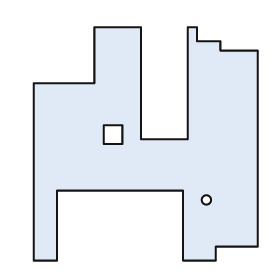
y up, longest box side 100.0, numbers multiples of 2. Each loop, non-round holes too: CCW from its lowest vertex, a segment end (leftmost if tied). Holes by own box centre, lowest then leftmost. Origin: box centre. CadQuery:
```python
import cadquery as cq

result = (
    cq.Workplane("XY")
    .moveTo(-48.0, -50.0)
    .lineTo(-38.0, -50.0)
    .lineTo(-38.0, -20.0)
    .lineTo(16.0, -20.0)
    .lineTo(16.0, -50.0)
    .lineTo(30.0, -50.0)
    .lineTo(30.0, -44.0)
    .lineTo(48.0, -44.0)
    .lineTo(48.0, 40.0)
    .lineTo(32.0, 40.0)
    .lineTo(32.0, 44.0)
    .lineTo(22.0, 44.0)
    .lineTo(22.0, 50.0)
    .lineTo(18.0, 50.0)
    .lineTo(18.0, 2.0)
    .lineTo(-2.0, 2.0)
    .lineTo(-2.0, 50.0)
    .lineTo(-22.0, 50.0)
    .lineTo(-22.0, 26.0)
    .lineTo(-48.0, 26.0)
    .close()
    .moveTo(26.0, -24.0)
    .circle(2.0)
    .moveTo(-18.0, 0.0)
    .lineTo(-10.0, 0.0)
    .lineTo(-10.0, 8.0)
    .lineTo(-18.0, 8.0)
    .close()
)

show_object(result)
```